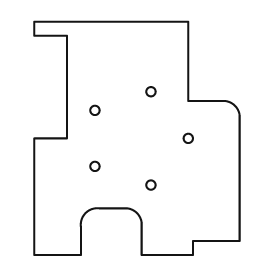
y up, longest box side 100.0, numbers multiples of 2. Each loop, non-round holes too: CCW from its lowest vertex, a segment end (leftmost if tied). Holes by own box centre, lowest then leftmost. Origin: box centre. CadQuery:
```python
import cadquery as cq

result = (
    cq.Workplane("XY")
    .moveTo(-44.0, -50.0)
    .lineTo(-24.0, -50.0)
    .lineTo(-24.0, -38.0)
    .threePointArc((-22.0, -32.0), (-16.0, -30.0))
    .lineTo(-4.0, -30.0)
    .threePointArc((0.0, -32.0), (2.0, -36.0))
    .lineTo(2.0, -50.0)
    .lineTo(24.0, -50.0)
    .lineTo(24.0, -44.0)
    .lineTo(44.0, -44.0)
    .lineTo(44.0, 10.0)
    .threePointArc((42.0, 14.0), (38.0, 16.0))
    .lineTo(22.0, 16.0)
    .lineTo(22.0, 50.0)
    .lineTo(-44.0, 50.0)
    .lineTo(-44.0, 44.0)
    .lineTo(-30.0, 44.0)
    .lineTo(-30.0, 0.0)
    .lineTo(-44.0, 0.0)
    .close()
    .moveTo(6.0, -20.0)
    .circle(2.0)
    .moveTo(-18.0, -12.0)
    .circle(2.0)
    .moveTo(22.0, 0.0)
    .circle(2.0)
    .moveTo(-18.0, 12.0)
    .circle(2.0)
    .moveTo(6.0, 20.0)
    .circle(2.0)
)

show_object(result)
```